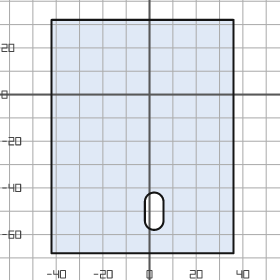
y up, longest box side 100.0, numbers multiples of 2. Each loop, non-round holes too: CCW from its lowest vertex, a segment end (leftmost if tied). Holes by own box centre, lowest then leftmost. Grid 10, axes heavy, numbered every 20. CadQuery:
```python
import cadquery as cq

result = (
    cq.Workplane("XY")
    .moveTo(-42.0, -68.0)
    .lineTo(36.0, -68.0)
    .lineTo(36.0, 32.0)
    .lineTo(-42.0, 32.0)
    .close()
    .moveTo(-2.0, -54.0)
    .threePointArc((2.0, -58.0), (6.0, -54.0))
    .lineTo(6.0, -46.0)
    .threePointArc((2.0, -42.0), (-2.0, -46.0))
    .close()
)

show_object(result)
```